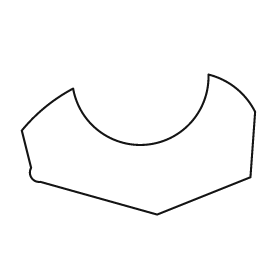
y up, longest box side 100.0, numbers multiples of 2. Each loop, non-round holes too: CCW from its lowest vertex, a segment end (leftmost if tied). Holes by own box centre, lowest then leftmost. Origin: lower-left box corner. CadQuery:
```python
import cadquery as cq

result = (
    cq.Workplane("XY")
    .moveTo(58.0, 0.0)
    .lineTo(98.0, 16.0)
    .lineTo(100.0, 44.0)
    .threePointArc((92.0, 54.0), (80.0, 60.0))
    .threePointArc((54.0, 30.0), (22.0, 54.0))
    .threePointArc((10.0, 46.0), (0.0, 36.0))
    .lineTo(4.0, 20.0)
    .threePointArc((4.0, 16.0), (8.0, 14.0))
    .close()
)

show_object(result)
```